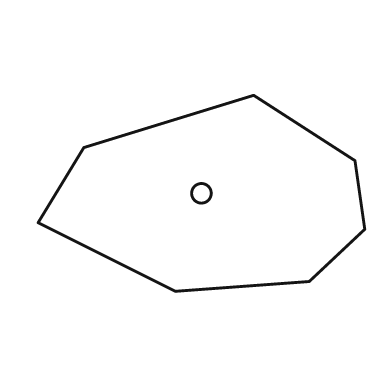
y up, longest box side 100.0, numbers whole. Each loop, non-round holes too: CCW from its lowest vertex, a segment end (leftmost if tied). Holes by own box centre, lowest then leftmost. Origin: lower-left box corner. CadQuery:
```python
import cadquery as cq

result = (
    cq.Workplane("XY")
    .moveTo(42.0, 0.0)
    .lineTo(83.0, 3.0)
    .lineTo(100.0, 19.0)
    .lineTo(97.0, 40.0)
    .lineTo(66.0, 60.0)
    .lineTo(14.0, 44.0)
    .lineTo(0.0, 21.0)
    .close()
    .moveTo(50.0, 30.0)
    .circle(3.0)
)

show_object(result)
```